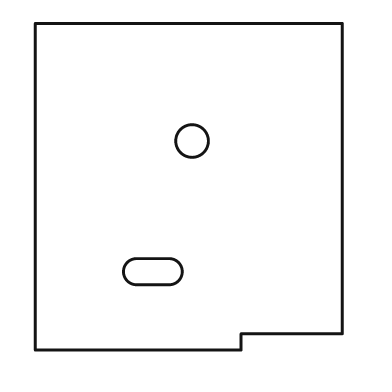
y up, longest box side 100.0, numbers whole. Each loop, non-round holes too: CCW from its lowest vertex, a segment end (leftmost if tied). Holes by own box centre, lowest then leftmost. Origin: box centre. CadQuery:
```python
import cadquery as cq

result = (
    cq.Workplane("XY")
    .moveTo(-47.0, -50.0)
    .lineTo(16.0, -50.0)
    .lineTo(16.0, -45.0)
    .lineTo(47.0, -45.0)
    .lineTo(47.0, 50.0)
    .lineTo(-47.0, 50.0)
    .close()
    .moveTo(-16.0, -30.0)
    .lineTo(-6.0, -30.0)
    .threePointArc((-2.0, -26.0), (-6.0, -22.0))
    .lineTo(-16.0, -22.0)
    .threePointArc((-20.0, -26.0), (-16.0, -30.0))
    .close()
    .moveTo(1.0, 14.0)
    .circle(5.0)
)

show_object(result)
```